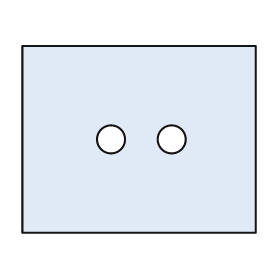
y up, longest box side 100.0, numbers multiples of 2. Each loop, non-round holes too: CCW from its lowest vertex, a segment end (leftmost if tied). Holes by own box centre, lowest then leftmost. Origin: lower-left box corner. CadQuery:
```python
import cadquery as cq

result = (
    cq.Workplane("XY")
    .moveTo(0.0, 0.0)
    .lineTo(100.0, 0.0)
    .lineTo(100.0, 80.0)
    .lineTo(0.0, 80.0)
    .close()
    .moveTo(38.0, 40.0)
    .circle(6.0)
    .moveTo(64.0, 40.0)
    .circle(6.0)
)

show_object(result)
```